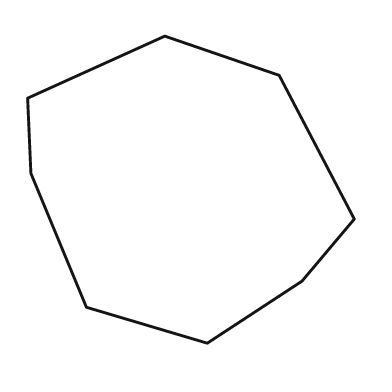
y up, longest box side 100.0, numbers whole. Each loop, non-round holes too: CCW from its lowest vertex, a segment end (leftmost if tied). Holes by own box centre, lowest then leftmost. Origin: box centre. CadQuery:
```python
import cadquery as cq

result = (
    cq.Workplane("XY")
    .moveTo(5.0, -47.0)
    .lineTo(34.0, -28.0)
    .lineTo(50.0, -9.0)
    .lineTo(27.0, 35.0)
    .lineTo(-8.0, 47.0)
    .lineTo(-50.0, 28.0)
    .lineTo(-49.0, 5.0)
    .lineTo(-32.0, -36.0)
    .close()
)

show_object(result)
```